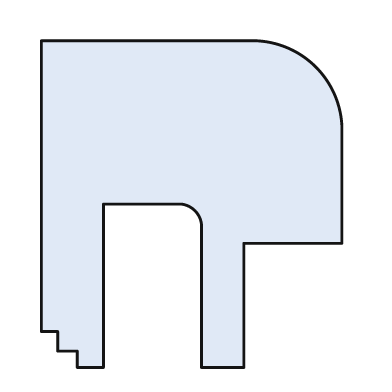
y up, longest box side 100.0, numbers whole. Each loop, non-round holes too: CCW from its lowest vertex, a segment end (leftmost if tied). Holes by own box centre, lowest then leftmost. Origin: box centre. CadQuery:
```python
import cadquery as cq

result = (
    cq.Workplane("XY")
    .moveTo(-35.0, -50.0)
    .lineTo(-27.0, -50.0)
    .lineTo(-27.0, 0.0)
    .lineTo(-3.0, 0.0)
    .threePointArc((1.0, -2.0), (3.0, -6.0))
    .lineTo(3.0, -50.0)
    .lineTo(16.0, -50.0)
    .lineTo(16.0, -12.0)
    .lineTo(46.0, -12.0)
    .lineTo(46.0, 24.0)
    .threePointArc((38.0, 42.0), (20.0, 50.0))
    .lineTo(-46.0, 50.0)
    .lineTo(-46.0, -39.0)
    .lineTo(-41.0, -39.0)
    .lineTo(-41.0, -45.0)
    .lineTo(-35.0, -45.0)
    .close()
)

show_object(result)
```